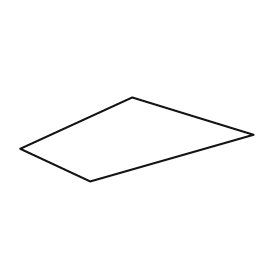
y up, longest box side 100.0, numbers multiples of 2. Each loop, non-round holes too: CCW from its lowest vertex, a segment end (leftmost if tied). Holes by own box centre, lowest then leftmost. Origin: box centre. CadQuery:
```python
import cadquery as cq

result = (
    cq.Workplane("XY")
    .moveTo(-20.0, -18.0)
    .lineTo(50.0, 2.0)
    .lineTo(-2.0, 18.0)
    .lineTo(-50.0, -4.0)
    .close()
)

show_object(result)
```